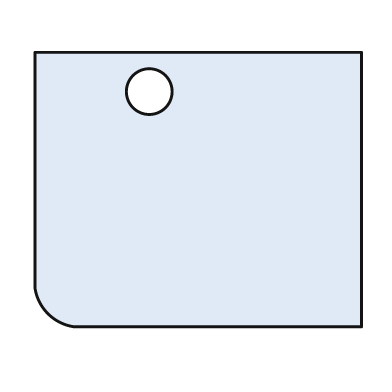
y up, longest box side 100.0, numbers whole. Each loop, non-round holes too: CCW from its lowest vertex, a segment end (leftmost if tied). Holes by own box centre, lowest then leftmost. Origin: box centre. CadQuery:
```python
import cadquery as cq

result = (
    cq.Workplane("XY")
    .moveTo(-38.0, -42.0)
    .lineTo(50.0, -42.0)
    .lineTo(50.0, 42.0)
    .lineTo(-50.0, 42.0)
    .lineTo(-50.0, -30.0)
    .threePointArc((-46.0, -38.0), (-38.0, -42.0))
    .close()
    .moveTo(-15.0, 30.0)
    .circle(7.0)
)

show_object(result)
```